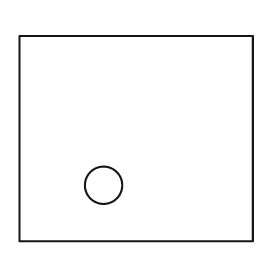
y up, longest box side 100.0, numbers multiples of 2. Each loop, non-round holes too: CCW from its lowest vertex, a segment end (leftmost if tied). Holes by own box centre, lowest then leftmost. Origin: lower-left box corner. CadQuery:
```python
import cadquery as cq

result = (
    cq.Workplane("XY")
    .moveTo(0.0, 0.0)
    .lineTo(100.0, 0.0)
    .lineTo(100.0, 88.0)
    .lineTo(0.0, 88.0)
    .close()
    .moveTo(36.0, 24.0)
    .circle(8.0)
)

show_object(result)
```